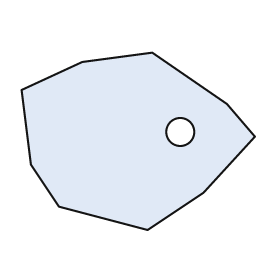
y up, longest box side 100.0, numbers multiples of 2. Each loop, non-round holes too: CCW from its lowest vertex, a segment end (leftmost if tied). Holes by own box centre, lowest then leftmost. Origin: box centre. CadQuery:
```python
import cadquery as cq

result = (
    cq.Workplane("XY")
    .moveTo(4.0, -38.0)
    .lineTo(28.0, -22.0)
    .lineTo(50.0, 2.0)
    .lineTo(38.0, 16.0)
    .lineTo(6.0, 38.0)
    .lineTo(-24.0, 34.0)
    .lineTo(-50.0, 22.0)
    .lineTo(-46.0, -10.0)
    .lineTo(-34.0, -28.0)
    .close()
    .moveTo(18.0, 4.0)
    .circle(6.0)
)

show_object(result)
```